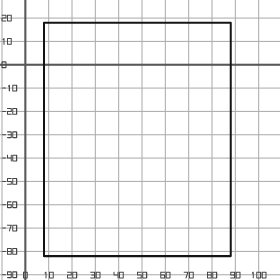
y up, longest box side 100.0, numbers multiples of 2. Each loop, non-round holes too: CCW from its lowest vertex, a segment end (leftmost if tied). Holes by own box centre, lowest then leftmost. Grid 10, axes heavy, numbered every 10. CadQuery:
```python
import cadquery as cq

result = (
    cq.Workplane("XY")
    .moveTo(8.0, -82.0)
    .lineTo(88.0, -82.0)
    .lineTo(88.0, 18.0)
    .lineTo(8.0, 18.0)
    .close()
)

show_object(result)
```